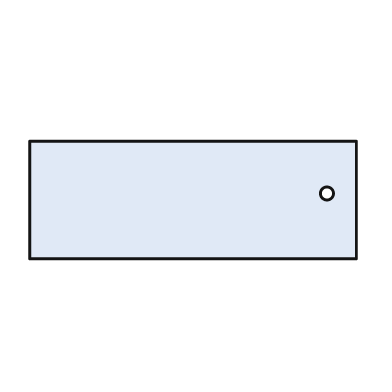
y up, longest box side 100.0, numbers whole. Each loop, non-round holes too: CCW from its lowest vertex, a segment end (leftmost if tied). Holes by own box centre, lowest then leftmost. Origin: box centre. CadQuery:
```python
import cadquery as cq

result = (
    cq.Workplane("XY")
    .moveTo(-50.0, -18.0)
    .lineTo(50.0, -18.0)
    .lineTo(50.0, 18.0)
    .lineTo(-50.0, 18.0)
    .close()
    .moveTo(41.0, 2.0)
    .circle(2.0)
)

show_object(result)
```